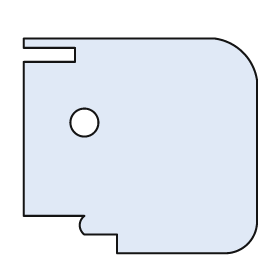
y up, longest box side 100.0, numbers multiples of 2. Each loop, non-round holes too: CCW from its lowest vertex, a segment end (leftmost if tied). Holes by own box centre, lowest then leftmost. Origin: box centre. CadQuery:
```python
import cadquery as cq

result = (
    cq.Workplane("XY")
    .moveTo(-10.0, -46.0)
    .lineTo(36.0, -46.0)
    .threePointArc((46.0, -42.0), (50.0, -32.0))
    .lineTo(50.0, 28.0)
    .threePointArc((44.0, 40.0), (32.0, 46.0))
    .lineTo(-50.0, 46.0)
    .lineTo(-50.0, 42.0)
    .lineTo(-28.0, 42.0)
    .lineTo(-28.0, 36.0)
    .lineTo(-50.0, 36.0)
    .lineTo(-50.0, -30.0)
    .lineTo(-24.0, -30.0)
    .threePointArc((-26.0, -34.0), (-24.0, -38.0))
    .lineTo(-10.0, -38.0)
    .close()
    .moveTo(-24.0, 10.0)
    .circle(6.0)
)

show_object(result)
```